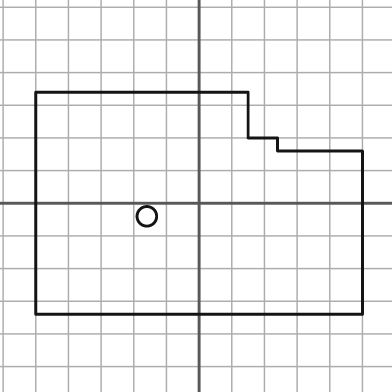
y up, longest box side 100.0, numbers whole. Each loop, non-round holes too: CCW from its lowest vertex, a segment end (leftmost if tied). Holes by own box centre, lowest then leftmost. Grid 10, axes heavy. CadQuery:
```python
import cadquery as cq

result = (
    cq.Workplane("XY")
    .moveTo(-50.0, -34.0)
    .lineTo(50.0, -34.0)
    .lineTo(50.0, 16.0)
    .lineTo(24.0, 16.0)
    .lineTo(24.0, 20.0)
    .lineTo(15.0, 20.0)
    .lineTo(15.0, 34.0)
    .lineTo(-50.0, 34.0)
    .close()
    .moveTo(-16.0, -4.0)
    .circle(3.0)
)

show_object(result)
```